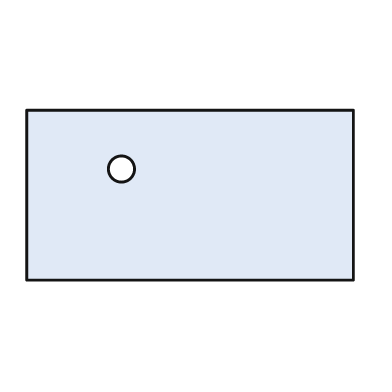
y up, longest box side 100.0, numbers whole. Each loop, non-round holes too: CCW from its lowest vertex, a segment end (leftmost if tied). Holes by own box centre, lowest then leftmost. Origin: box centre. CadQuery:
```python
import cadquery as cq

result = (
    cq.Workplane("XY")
    .moveTo(-50.0, -26.0)
    .lineTo(50.0, -26.0)
    .lineTo(50.0, 26.0)
    .lineTo(-50.0, 26.0)
    .close()
    .moveTo(-21.0, 8.0)
    .circle(4.0)
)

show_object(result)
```